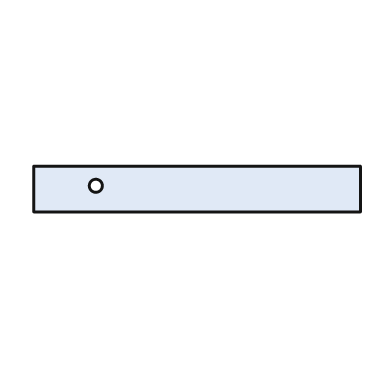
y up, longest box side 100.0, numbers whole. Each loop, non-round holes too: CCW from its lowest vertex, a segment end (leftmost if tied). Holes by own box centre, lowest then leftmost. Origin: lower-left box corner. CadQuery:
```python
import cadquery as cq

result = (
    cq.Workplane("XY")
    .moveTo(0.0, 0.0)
    .lineTo(100.0, 0.0)
    .lineTo(100.0, 14.0)
    .lineTo(0.0, 14.0)
    .close()
    .moveTo(19.0, 8.0)
    .circle(2.0)
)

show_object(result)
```